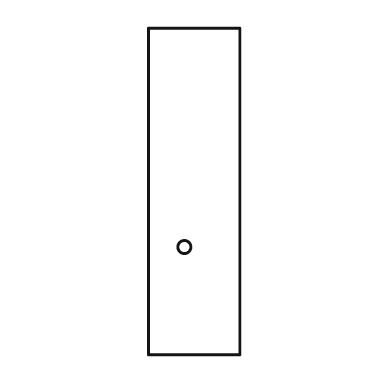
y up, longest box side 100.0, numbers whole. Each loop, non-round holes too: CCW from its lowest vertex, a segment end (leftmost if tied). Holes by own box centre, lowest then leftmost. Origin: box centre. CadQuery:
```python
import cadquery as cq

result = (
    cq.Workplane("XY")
    .moveTo(-14.0, -50.0)
    .lineTo(14.0, -50.0)
    .lineTo(14.0, 50.0)
    .lineTo(-14.0, 50.0)
    .close()
    .moveTo(-3.0, -17.0)
    .circle(2.0)
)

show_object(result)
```